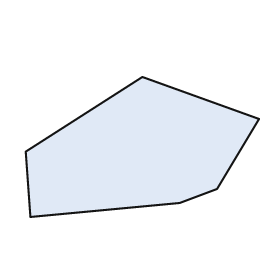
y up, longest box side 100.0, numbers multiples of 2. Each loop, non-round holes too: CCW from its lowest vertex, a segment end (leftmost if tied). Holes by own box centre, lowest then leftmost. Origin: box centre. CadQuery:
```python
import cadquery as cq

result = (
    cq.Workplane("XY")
    .moveTo(-48.0, -30.0)
    .lineTo(16.0, -24.0)
    .lineTo(32.0, -18.0)
    .lineTo(50.0, 12.0)
    .lineTo(0.0, 30.0)
    .lineTo(-50.0, -2.0)
    .close()
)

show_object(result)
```